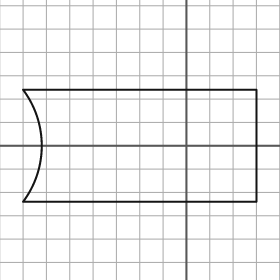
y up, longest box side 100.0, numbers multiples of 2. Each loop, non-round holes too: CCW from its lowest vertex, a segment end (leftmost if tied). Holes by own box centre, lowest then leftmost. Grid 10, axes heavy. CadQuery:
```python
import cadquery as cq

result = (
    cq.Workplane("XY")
    .moveTo(-70.0, -24.0)
    .lineTo(30.0, -24.0)
    .lineTo(30.0, 24.0)
    .lineTo(-70.0, 24.0)
    .threePointArc((-62.0, 0.0), (-70.0, -24.0))
    .close()
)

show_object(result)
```